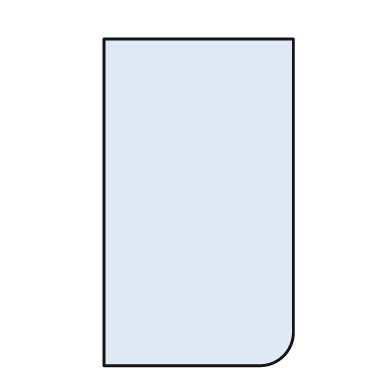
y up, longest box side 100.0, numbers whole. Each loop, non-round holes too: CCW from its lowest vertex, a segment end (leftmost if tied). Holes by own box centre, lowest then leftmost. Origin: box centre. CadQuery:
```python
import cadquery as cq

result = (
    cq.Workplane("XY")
    .moveTo(-29.0, -50.0)
    .lineTo(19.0, -50.0)
    .threePointArc((26.0, -47.0), (29.0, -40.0))
    .lineTo(29.0, 50.0)
    .lineTo(-29.0, 50.0)
    .close()
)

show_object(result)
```